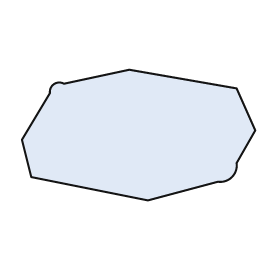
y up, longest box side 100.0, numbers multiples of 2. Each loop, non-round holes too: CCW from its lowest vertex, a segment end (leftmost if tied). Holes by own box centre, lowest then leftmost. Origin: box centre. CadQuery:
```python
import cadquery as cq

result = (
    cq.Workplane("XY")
    .moveTo(4.0, -28.0)
    .lineTo(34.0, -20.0)
    .threePointArc((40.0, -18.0), (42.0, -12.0))
    .lineTo(50.0, 2.0)
    .lineTo(42.0, 20.0)
    .lineTo(-4.0, 28.0)
    .lineTo(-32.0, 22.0)
    .threePointArc((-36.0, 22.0), (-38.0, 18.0))
    .lineTo(-50.0, -2.0)
    .lineTo(-46.0, -18.0)
    .close()
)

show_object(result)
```